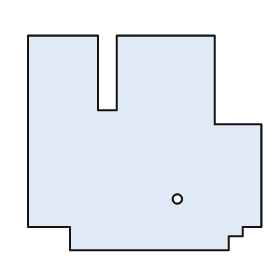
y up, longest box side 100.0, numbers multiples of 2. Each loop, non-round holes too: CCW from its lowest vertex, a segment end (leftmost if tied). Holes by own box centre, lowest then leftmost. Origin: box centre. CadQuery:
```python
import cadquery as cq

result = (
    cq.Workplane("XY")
    .moveTo(-32.0, -46.0)
    .lineTo(36.0, -46.0)
    .lineTo(36.0, -40.0)
    .lineTo(42.0, -40.0)
    .lineTo(42.0, -36.0)
    .lineTo(50.0, -36.0)
    .lineTo(50.0, 8.0)
    .lineTo(30.0, 8.0)
    .lineTo(30.0, 46.0)
    .lineTo(-12.0, 46.0)
    .lineTo(-12.0, 14.0)
    .lineTo(-20.0, 14.0)
    .lineTo(-20.0, 46.0)
    .lineTo(-50.0, 46.0)
    .lineTo(-50.0, -36.0)
    .lineTo(-32.0, -36.0)
    .close()
    .moveTo(14.0, -24.0)
    .circle(2.0)
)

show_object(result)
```